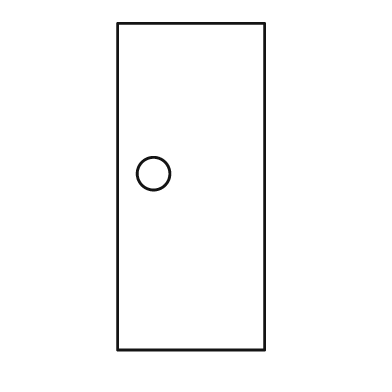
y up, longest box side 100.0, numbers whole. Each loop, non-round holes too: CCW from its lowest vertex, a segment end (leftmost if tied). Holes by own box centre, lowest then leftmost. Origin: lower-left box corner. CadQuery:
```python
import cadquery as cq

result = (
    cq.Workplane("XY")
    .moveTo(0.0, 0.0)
    .lineTo(45.0, 0.0)
    .lineTo(45.0, 100.0)
    .lineTo(0.0, 100.0)
    .close()
    .moveTo(11.0, 54.0)
    .circle(5.0)
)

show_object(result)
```